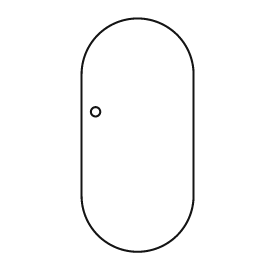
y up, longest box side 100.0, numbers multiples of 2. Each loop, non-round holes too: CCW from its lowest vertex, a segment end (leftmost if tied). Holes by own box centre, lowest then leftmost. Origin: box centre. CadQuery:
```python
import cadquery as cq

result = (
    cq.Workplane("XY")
    .moveTo(-24.0, -26.0)
    .threePointArc((0.0, -50.0), (24.0, -26.0))
    .lineTo(24.0, 26.0)
    .threePointArc((0.0, 50.0), (-24.0, 26.0))
    .close()
    .moveTo(-18.0, 10.0)
    .circle(2.0)
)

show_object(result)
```